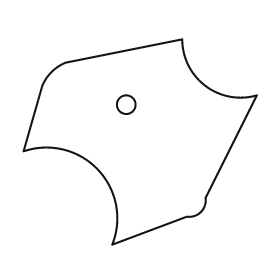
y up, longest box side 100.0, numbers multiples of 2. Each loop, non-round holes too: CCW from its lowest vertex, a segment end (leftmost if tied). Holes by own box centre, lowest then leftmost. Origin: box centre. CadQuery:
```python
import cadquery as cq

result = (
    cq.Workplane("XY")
    .moveTo(-12.0, -44.0)
    .lineTo(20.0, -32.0)
    .threePointArc((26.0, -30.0), (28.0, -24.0))
    .lineTo(50.0, 20.0)
    .threePointArc((28.0, 24.0), (18.0, 44.0))
    .lineTo(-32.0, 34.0)
    .threePointArc((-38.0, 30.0), (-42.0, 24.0))
    .lineTo(-50.0, -4.0)
    .threePointArc((-18.0, -12.0), (-12.0, -44.0))
    .close()
    .moveTo(-6.0, 16.0)
    .circle(4.0)
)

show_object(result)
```